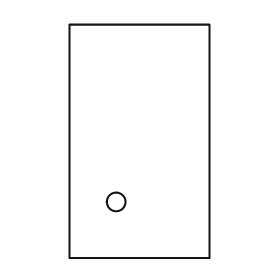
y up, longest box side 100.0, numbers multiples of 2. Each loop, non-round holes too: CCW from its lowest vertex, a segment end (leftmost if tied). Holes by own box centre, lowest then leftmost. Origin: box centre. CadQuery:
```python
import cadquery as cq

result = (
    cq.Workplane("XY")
    .moveTo(-30.0, -50.0)
    .lineTo(30.0, -50.0)
    .lineTo(30.0, 50.0)
    .lineTo(-30.0, 50.0)
    .close()
    .moveTo(-10.0, -26.0)
    .circle(4.0)
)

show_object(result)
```